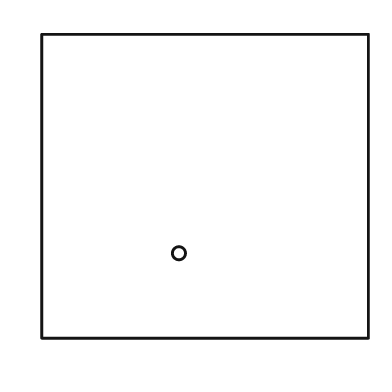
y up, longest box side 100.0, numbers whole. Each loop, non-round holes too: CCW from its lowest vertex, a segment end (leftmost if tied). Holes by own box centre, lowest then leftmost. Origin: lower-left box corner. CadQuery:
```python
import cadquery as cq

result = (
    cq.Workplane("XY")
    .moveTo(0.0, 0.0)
    .lineTo(100.0, 0.0)
    .lineTo(100.0, 93.0)
    .lineTo(0.0, 93.0)
    .close()
    .moveTo(42.0, 26.0)
    .circle(2.0)
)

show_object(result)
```